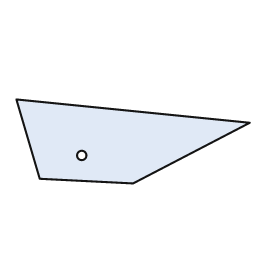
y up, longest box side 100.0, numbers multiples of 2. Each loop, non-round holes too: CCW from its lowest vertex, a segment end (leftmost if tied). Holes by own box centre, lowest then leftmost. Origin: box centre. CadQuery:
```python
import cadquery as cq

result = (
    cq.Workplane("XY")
    .moveTo(0.0, -18.0)
    .lineTo(50.0, 8.0)
    .lineTo(-50.0, 18.0)
    .lineTo(-40.0, -16.0)
    .close()
    .moveTo(-22.0, -6.0)
    .circle(2.0)
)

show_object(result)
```